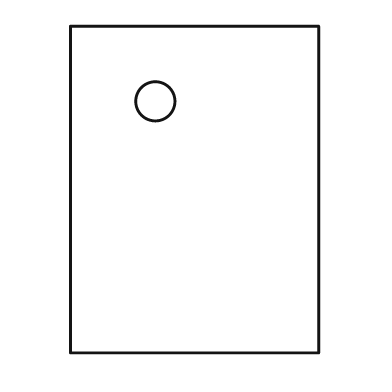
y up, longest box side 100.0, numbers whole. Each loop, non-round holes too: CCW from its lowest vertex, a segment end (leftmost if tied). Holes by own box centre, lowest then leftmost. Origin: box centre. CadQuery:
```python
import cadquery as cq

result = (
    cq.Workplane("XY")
    .moveTo(-38.0, -50.0)
    .lineTo(38.0, -50.0)
    .lineTo(38.0, 50.0)
    .lineTo(-38.0, 50.0)
    .close()
    .moveTo(-12.0, 27.0)
    .circle(6.0)
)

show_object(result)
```